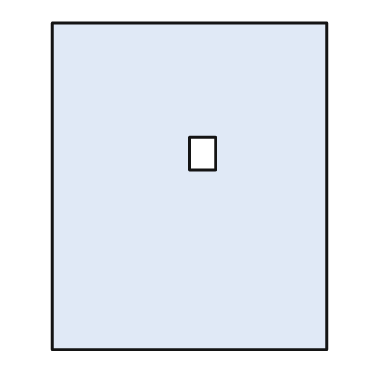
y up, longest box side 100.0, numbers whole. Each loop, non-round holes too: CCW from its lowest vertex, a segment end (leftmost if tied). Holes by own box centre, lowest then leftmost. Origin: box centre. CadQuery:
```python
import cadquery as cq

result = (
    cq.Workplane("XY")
    .moveTo(-42.0, -50.0)
    .lineTo(42.0, -50.0)
    .lineTo(42.0, 50.0)
    .lineTo(-42.0, 50.0)
    .close()
    .moveTo(0.0, 5.0)
    .lineTo(8.0, 5.0)
    .lineTo(8.0, 15.0)
    .lineTo(0.0, 15.0)
    .close()
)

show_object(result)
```